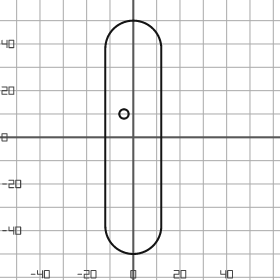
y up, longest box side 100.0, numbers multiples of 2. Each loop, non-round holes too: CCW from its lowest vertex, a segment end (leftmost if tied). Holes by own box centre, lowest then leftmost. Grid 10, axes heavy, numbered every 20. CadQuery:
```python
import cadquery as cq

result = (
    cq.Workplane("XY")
    .moveTo(-12.0, -38.0)
    .threePointArc((0.0, -50.0), (12.0, -38.0))
    .lineTo(12.0, 38.0)
    .threePointArc((0.0, 50.0), (-12.0, 38.0))
    .close()
    .moveTo(-4.0, 10.0)
    .circle(2.0)
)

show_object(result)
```